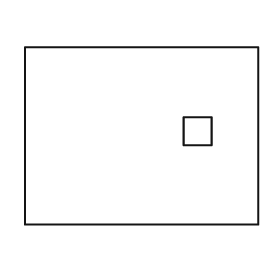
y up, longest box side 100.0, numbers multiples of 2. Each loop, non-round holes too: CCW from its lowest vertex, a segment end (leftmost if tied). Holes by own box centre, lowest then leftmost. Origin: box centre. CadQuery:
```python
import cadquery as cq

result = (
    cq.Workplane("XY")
    .moveTo(-50.0, -38.0)
    .lineTo(50.0, -38.0)
    .lineTo(50.0, 38.0)
    .lineTo(-50.0, 38.0)
    .close()
    .moveTo(18.0, -4.0)
    .lineTo(30.0, -4.0)
    .lineTo(30.0, 8.0)
    .lineTo(18.0, 8.0)
    .close()
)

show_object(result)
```